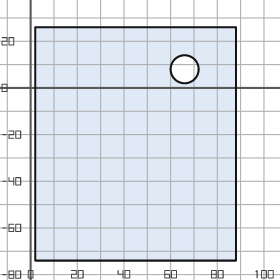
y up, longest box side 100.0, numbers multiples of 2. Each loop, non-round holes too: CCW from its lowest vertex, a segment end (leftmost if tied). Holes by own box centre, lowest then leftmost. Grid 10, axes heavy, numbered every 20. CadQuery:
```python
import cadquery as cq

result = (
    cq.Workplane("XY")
    .moveTo(2.0, -74.0)
    .lineTo(88.0, -74.0)
    .lineTo(88.0, 26.0)
    .lineTo(2.0, 26.0)
    .close()
    .moveTo(66.0, 8.0)
    .circle(6.0)
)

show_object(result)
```